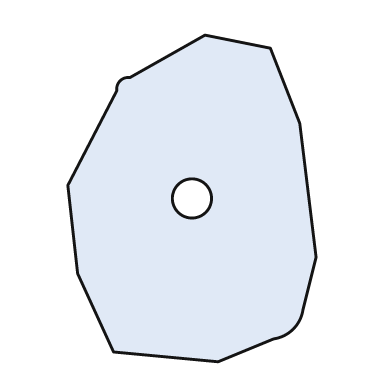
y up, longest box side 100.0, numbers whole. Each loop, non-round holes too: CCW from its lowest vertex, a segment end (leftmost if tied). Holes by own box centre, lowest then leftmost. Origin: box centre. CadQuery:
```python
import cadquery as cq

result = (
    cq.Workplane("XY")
    .moveTo(8.0, -50.0)
    .lineTo(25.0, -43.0)
    .threePointArc((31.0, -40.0), (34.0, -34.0))
    .lineTo(38.0, -18.0)
    .lineTo(33.0, 23.0)
    .lineTo(24.0, 46.0)
    .lineTo(4.0, 50.0)
    .lineTo(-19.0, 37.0)
    .threePointArc((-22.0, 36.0), (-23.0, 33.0))
    .lineTo(-38.0, 4.0)
    .lineTo(-35.0, -23.0)
    .lineTo(-24.0, -47.0)
    .close()
    .moveTo(0.0, 0.0)
    .circle(6.0)
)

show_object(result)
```